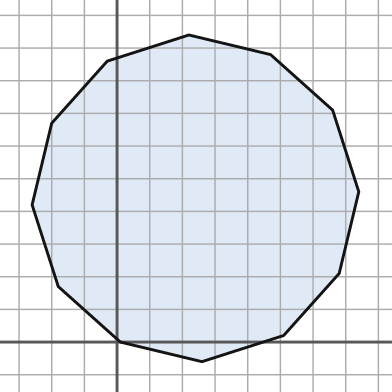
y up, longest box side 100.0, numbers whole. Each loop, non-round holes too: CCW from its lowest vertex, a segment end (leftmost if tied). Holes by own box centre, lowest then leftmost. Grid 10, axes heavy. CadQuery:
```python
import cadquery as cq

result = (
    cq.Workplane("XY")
    .moveTo(26.0, -6.0)
    .lineTo(51.0, 2.0)
    .lineTo(68.0, 21.0)
    .lineTo(74.0, 46.0)
    .lineTo(66.0, 71.0)
    .lineTo(47.0, 88.0)
    .lineTo(22.0, 94.0)
    .lineTo(-3.0, 86.0)
    .lineTo(-20.0, 67.0)
    .lineTo(-26.0, 42.0)
    .lineTo(-18.0, 17.0)
    .lineTo(1.0, 0.0)
    .close()
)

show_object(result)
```